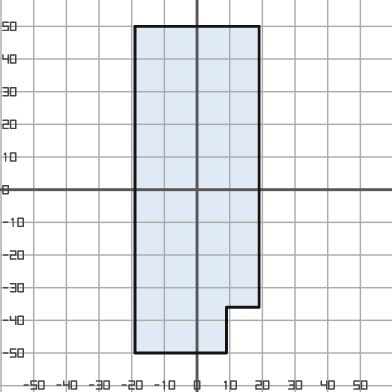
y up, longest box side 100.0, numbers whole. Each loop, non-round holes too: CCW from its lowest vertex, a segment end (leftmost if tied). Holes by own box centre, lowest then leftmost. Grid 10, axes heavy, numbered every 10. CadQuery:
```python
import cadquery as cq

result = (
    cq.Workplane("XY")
    .moveTo(-19.0, -50.0)
    .lineTo(9.0, -50.0)
    .lineTo(9.0, -36.0)
    .lineTo(19.0, -36.0)
    .lineTo(19.0, 50.0)
    .lineTo(-19.0, 50.0)
    .close()
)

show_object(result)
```